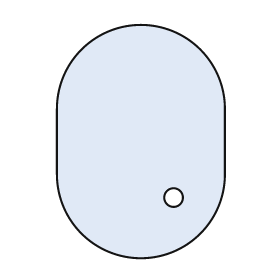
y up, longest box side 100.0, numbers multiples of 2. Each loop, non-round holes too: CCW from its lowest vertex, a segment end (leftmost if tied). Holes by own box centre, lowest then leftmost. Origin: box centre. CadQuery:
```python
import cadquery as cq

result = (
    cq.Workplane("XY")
    .moveTo(-36.0, -14.0)
    .threePointArc((0.0, -50.0), (36.0, -14.0))
    .lineTo(36.0, 14.0)
    .threePointArc((0.0, 50.0), (-36.0, 14.0))
    .close()
    .moveTo(14.0, -24.0)
    .circle(4.0)
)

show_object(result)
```